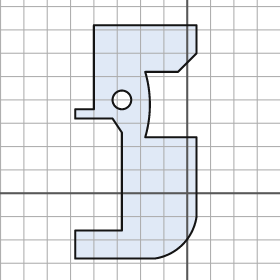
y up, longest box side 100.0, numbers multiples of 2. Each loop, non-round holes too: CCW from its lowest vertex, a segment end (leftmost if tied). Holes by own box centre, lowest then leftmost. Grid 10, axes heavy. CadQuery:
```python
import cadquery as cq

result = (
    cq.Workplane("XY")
    .moveTo(-48.0, -28.0)
    .lineTo(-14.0, -28.0)
    .threePointArc((-2.0, -22.0), (4.0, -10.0))
    .lineTo(4.0, 24.0)
    .lineTo(-18.0, 24.0)
    .threePointArc((-16.0, 38.0), (-18.0, 52.0))
    .lineTo(-4.0, 52.0)
    .lineTo(4.0, 60.0)
    .lineTo(4.0, 72.0)
    .lineTo(-40.0, 72.0)
    .lineTo(-40.0, 36.0)
    .lineTo(-48.0, 36.0)
    .lineTo(-48.0, 32.0)
    .lineTo(-32.0, 32.0)
    .lineTo(-28.0, 26.0)
    .lineTo(-28.0, -16.0)
    .lineTo(-48.0, -16.0)
    .close()
    .moveTo(-28.0, 40.0)
    .circle(4.0)
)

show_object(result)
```